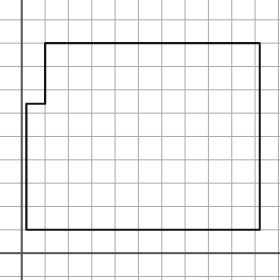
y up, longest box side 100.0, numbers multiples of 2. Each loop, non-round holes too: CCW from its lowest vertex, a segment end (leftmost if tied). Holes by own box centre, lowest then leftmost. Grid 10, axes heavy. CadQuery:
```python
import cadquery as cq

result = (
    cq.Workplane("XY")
    .moveTo(2.0, 10.0)
    .lineTo(102.0, 10.0)
    .lineTo(102.0, 90.0)
    .lineTo(10.0, 90.0)
    .lineTo(10.0, 64.0)
    .lineTo(2.0, 64.0)
    .close()
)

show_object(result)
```